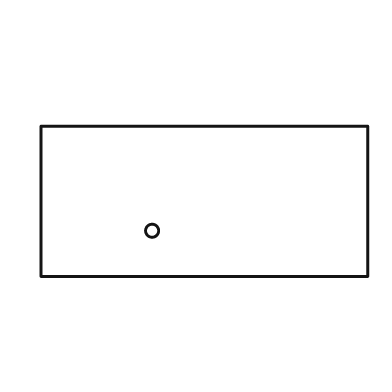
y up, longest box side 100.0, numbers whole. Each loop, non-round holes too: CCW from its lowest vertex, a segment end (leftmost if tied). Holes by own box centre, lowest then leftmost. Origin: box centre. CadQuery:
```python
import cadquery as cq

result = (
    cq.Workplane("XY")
    .moveTo(-50.0, -23.0)
    .lineTo(50.0, -23.0)
    .lineTo(50.0, 23.0)
    .lineTo(-50.0, 23.0)
    .close()
    .moveTo(-16.0, -9.0)
    .circle(2.0)
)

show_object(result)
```